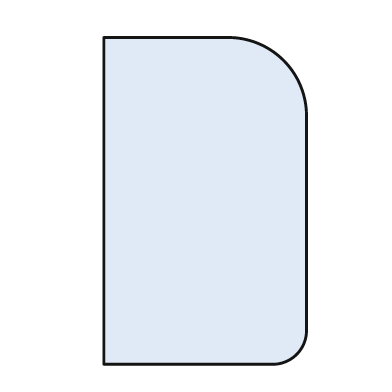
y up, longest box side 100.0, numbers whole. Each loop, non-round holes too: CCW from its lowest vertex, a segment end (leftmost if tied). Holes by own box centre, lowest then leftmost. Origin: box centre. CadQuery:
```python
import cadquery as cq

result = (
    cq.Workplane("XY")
    .moveTo(-31.0, -50.0)
    .lineTo(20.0, -50.0)
    .threePointArc((28.0, -47.0), (31.0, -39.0))
    .lineTo(31.0, 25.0)
    .threePointArc((24.0, 43.0), (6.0, 50.0))
    .lineTo(-31.0, 50.0)
    .close()
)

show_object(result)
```